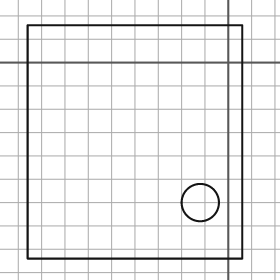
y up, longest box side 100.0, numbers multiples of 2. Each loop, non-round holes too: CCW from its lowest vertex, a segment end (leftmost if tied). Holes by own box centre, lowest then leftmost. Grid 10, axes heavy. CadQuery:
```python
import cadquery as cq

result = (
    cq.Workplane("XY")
    .moveTo(-86.0, -84.0)
    .lineTo(6.0, -84.0)
    .lineTo(6.0, 16.0)
    .lineTo(-86.0, 16.0)
    .close()
    .moveTo(-12.0, -60.0)
    .circle(8.0)
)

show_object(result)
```